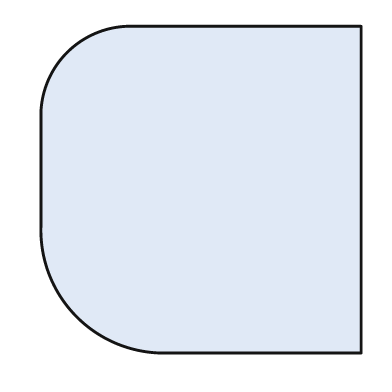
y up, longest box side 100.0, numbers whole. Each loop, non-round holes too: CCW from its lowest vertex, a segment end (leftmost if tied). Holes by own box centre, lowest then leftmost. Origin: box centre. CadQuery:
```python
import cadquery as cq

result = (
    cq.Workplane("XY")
    .moveTo(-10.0, -50.0)
    .lineTo(49.0, -50.0)
    .lineTo(49.0, 50.0)
    .lineTo(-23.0, 50.0)
    .threePointArc((-41.0, 42.0), (-49.0, 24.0))
    .lineTo(-49.0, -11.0)
    .threePointArc((-38.0, -39.0), (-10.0, -50.0))
    .close()
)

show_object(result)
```